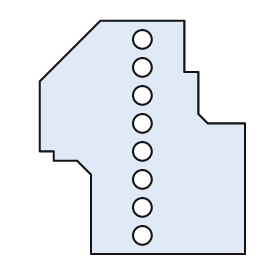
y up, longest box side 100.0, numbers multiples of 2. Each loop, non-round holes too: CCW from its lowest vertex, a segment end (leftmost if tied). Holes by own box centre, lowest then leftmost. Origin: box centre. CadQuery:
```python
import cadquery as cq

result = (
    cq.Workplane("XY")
    .moveTo(-22.0, -50.0)
    .lineTo(44.0, -50.0)
    .lineTo(44.0, 6.0)
    .lineTo(28.0, 6.0)
    .lineTo(24.0, 10.0)
    .lineTo(24.0, 28.0)
    .lineTo(18.0, 28.0)
    .lineTo(18.0, 50.0)
    .lineTo(-18.0, 50.0)
    .lineTo(-44.0, 24.0)
    .lineTo(-44.0, -6.0)
    .lineTo(-38.0, -6.0)
    .lineTo(-38.0, -10.0)
    .lineTo(-28.0, -10.0)
    .lineTo(-22.0, -16.0)
    .close()
    .moveTo(0.0, -42.0)
    .circle(4.0)
    .moveTo(0.0, -30.0)
    .circle(4.0)
    .moveTo(0.0, -18.0)
    .circle(4.0)
    .moveTo(0.0, -6.0)
    .circle(4.0)
    .moveTo(0.0, 6.0)
    .circle(4.0)
    .moveTo(0.0, 18.0)
    .circle(4.0)
    .moveTo(0.0, 30.0)
    .circle(4.0)
    .moveTo(0.0, 42.0)
    .circle(4.0)
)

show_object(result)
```